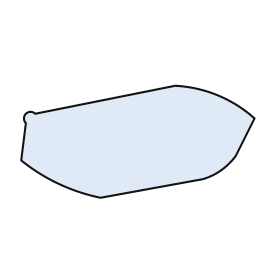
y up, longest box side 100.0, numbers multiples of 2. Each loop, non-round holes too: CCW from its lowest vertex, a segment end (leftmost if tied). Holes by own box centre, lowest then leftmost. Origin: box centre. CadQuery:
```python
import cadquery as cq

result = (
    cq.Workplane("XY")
    .moveTo(-16.0, -24.0)
    .lineTo(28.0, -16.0)
    .threePointArc((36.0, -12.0), (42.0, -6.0))
    .lineTo(50.0, 10.0)
    .threePointArc((34.0, 20.0), (16.0, 24.0))
    .lineTo(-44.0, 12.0)
    .threePointArc((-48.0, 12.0), (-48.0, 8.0))
    .lineTo(-50.0, -8.0)
    .threePointArc((-34.0, -18.0), (-16.0, -24.0))
    .close()
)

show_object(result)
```